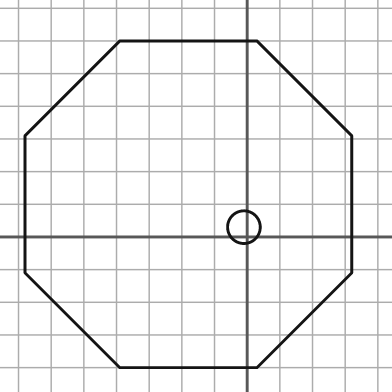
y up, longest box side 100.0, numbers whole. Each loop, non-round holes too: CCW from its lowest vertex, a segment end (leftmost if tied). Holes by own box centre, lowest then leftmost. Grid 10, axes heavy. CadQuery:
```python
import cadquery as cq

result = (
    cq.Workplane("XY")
    .moveTo(-39.0, -40.0)
    .lineTo(3.0, -40.0)
    .lineTo(32.0, -11.0)
    .lineTo(32.0, 31.0)
    .lineTo(3.0, 60.0)
    .lineTo(-39.0, 60.0)
    .lineTo(-68.0, 31.0)
    .lineTo(-68.0, -11.0)
    .close()
    .moveTo(-1.0, 3.0)
    .circle(5.0)
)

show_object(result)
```